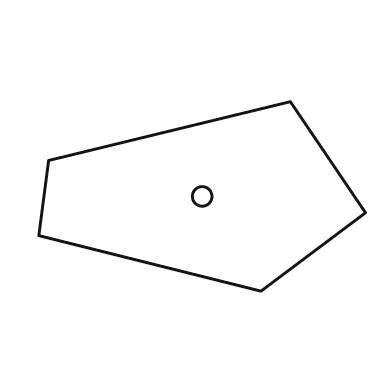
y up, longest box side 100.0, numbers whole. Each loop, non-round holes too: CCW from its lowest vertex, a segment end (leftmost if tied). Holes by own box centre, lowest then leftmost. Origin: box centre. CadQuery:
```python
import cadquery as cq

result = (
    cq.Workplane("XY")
    .moveTo(18.0, -29.0)
    .lineTo(50.0, -5.0)
    .lineTo(27.0, 29.0)
    .lineTo(-47.0, 11.0)
    .lineTo(-50.0, -12.0)
    .close()
    .moveTo(0.0, 0.0)
    .circle(3.0)
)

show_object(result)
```